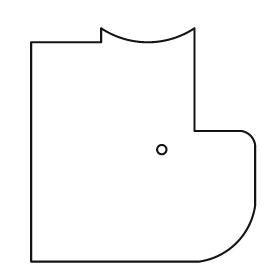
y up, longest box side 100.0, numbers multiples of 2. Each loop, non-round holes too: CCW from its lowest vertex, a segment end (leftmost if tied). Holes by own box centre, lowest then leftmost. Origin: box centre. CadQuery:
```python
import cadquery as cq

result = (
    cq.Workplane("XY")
    .moveTo(-48.0, -50.0)
    .lineTo(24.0, -50.0)
    .threePointArc((40.0, -42.0), (48.0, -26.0))
    .lineTo(48.0, 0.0)
    .threePointArc((46.0, 4.0), (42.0, 6.0))
    .lineTo(22.0, 6.0)
    .lineTo(22.0, 50.0)
    .threePointArc((2.0, 44.0), (-18.0, 50.0))
    .lineTo(-18.0, 44.0)
    .lineTo(-48.0, 44.0)
    .close()
    .moveTo(8.0, -2.0)
    .circle(2.0)
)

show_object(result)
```